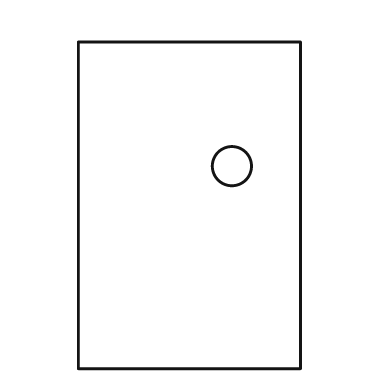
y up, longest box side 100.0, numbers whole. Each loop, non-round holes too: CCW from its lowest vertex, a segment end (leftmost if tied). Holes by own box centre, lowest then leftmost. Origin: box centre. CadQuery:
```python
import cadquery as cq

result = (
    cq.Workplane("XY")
    .moveTo(-34.0, -50.0)
    .lineTo(34.0, -50.0)
    .lineTo(34.0, 50.0)
    .lineTo(-34.0, 50.0)
    .close()
    .moveTo(13.0, 12.0)
    .circle(6.0)
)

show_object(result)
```